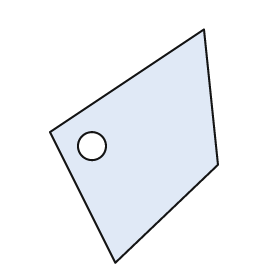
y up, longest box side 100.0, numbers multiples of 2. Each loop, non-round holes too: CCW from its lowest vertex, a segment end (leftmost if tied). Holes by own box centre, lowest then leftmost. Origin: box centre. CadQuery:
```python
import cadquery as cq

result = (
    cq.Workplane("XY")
    .moveTo(-8.0, -50.0)
    .lineTo(36.0, -8.0)
    .lineTo(30.0, 50.0)
    .lineTo(-36.0, 6.0)
    .close()
    .moveTo(-18.0, 0.0)
    .circle(6.0)
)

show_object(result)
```